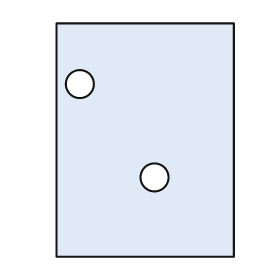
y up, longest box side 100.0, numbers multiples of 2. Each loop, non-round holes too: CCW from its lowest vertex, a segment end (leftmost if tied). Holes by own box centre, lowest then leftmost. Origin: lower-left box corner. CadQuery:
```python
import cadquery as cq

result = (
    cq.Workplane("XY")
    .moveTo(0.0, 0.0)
    .lineTo(76.0, 0.0)
    .lineTo(76.0, 100.0)
    .lineTo(0.0, 100.0)
    .close()
    .moveTo(42.0, 34.0)
    .circle(6.0)
    .moveTo(10.0, 74.0)
    .circle(6.0)
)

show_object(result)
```